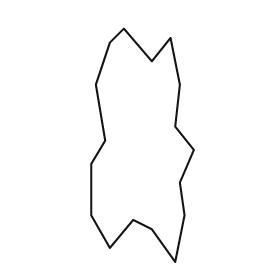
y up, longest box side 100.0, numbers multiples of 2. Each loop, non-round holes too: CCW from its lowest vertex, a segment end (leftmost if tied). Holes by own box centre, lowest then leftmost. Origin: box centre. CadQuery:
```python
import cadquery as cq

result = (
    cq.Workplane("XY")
    .moveTo(14.0, -50.0)
    .lineTo(18.0, -30.0)
    .lineTo(16.0, -16.0)
    .lineTo(22.0, -2.0)
    .lineTo(14.0, 8.0)
    .lineTo(16.0, 26.0)
    .lineTo(12.0, 46.0)
    .lineTo(4.0, 36.0)
    .lineTo(-8.0, 50.0)
    .lineTo(-14.0, 44.0)
    .lineTo(-20.0, 26.0)
    .lineTo(-16.0, 2.0)
    .lineTo(-22.0, -8.0)
    .lineTo(-22.0, -30.0)
    .lineTo(-14.0, -44.0)
    .lineTo(-4.0, -32.0)
    .lineTo(4.0, -36.0)
    .close()
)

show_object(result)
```